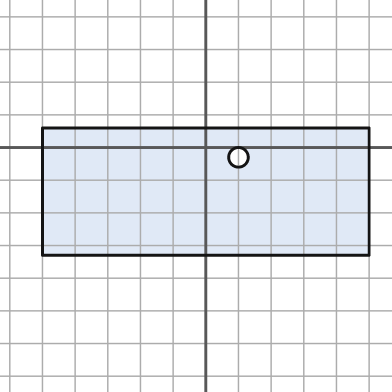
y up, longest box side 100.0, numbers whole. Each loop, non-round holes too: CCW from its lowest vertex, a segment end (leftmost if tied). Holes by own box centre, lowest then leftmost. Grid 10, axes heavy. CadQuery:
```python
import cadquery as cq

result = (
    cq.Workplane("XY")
    .moveTo(-50.0, -33.0)
    .lineTo(50.0, -33.0)
    .lineTo(50.0, 6.0)
    .lineTo(-50.0, 6.0)
    .close()
    .moveTo(10.0, -3.0)
    .circle(3.0)
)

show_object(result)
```